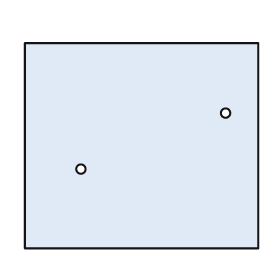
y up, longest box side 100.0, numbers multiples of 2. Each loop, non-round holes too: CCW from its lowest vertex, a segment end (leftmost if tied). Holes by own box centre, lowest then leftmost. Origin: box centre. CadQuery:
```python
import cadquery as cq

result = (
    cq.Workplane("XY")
    .moveTo(-50.0, -44.0)
    .lineTo(50.0, -44.0)
    .lineTo(50.0, 44.0)
    .lineTo(-50.0, 44.0)
    .close()
    .moveTo(-26.0, -10.0)
    .circle(2.0)
    .moveTo(36.0, 14.0)
    .circle(2.0)
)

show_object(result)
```